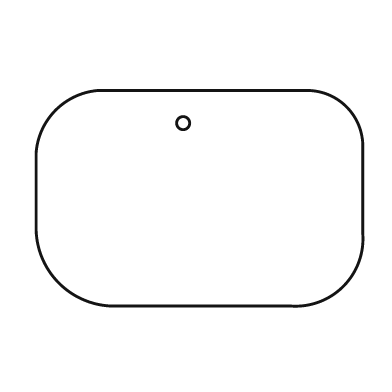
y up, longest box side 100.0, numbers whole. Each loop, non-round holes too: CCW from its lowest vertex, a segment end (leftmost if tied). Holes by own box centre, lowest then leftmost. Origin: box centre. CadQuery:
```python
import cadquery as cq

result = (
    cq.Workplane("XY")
    .moveTo(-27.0, -33.0)
    .lineTo(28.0, -33.0)
    .threePointArc((44.0, -27.0), (50.0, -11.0))
    .lineTo(50.0, 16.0)
    .threePointArc((45.0, 28.0), (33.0, 33.0))
    .lineTo(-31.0, 33.0)
    .threePointArc((-44.0, 27.0), (-50.0, 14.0))
    .lineTo(-50.0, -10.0)
    .threePointArc((-43.0, -26.0), (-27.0, -33.0))
    .close()
    .moveTo(-5.0, 23.0)
    .circle(2.0)
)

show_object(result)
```